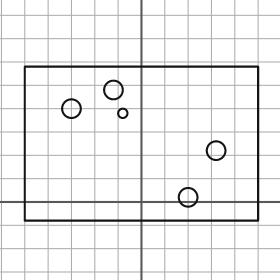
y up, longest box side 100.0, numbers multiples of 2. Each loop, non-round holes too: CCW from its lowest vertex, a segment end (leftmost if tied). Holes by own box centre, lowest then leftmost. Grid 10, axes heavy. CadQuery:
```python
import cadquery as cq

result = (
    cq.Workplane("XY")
    .moveTo(-50.0, -8.0)
    .lineTo(50.0, -8.0)
    .lineTo(50.0, 58.0)
    .lineTo(-50.0, 58.0)
    .close()
    .moveTo(20.0, 2.0)
    .circle(4.0)
    .moveTo(32.0, 22.0)
    .circle(4.0)
    .moveTo(-8.0, 38.0)
    .circle(2.0)
    .moveTo(-30.0, 40.0)
    .circle(4.0)
    .moveTo(-12.0, 48.0)
    .circle(4.0)
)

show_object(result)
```